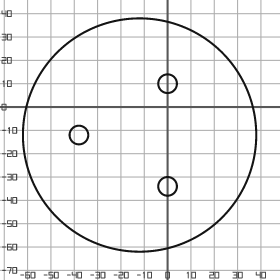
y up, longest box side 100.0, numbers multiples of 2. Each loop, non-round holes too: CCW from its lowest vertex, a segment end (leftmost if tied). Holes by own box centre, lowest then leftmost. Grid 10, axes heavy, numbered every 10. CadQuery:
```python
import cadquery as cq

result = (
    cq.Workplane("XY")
    .moveTo(-12.0, -12.0)
    .circle(50.0)
    .moveTo(0.0, -34.0)
    .circle(4.0)
    .moveTo(-38.0, -12.0)
    .circle(4.0)
    .moveTo(0.0, 10.0)
    .circle(4.0)
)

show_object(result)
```